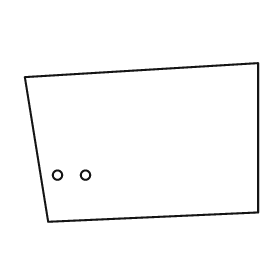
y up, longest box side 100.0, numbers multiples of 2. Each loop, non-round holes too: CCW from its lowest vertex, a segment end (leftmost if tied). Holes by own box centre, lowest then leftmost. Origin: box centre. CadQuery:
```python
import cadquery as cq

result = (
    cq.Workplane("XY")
    .moveTo(-40.0, -34.0)
    .lineTo(50.0, -30.0)
    .lineTo(50.0, 34.0)
    .lineTo(-50.0, 28.0)
    .close()
    .moveTo(-36.0, -14.0)
    .circle(2.0)
    .moveTo(-24.0, -14.0)
    .circle(2.0)
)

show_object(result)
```